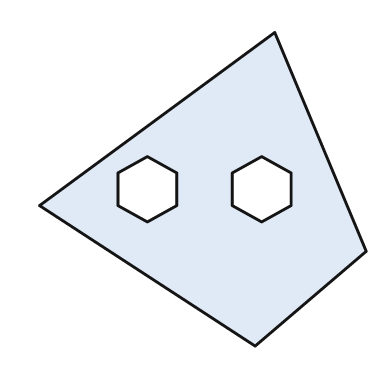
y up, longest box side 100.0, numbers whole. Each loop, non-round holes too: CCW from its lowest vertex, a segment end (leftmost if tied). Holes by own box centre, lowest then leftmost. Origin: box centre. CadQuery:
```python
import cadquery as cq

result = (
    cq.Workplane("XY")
    .moveTo(16.0, -48.0)
    .lineTo(50.0, -19.0)
    .lineTo(22.0, 48.0)
    .lineTo(-50.0, -5.0)
    .close()
    .moveTo(-17.0, -10.0)
    .lineTo(-8.0, -5.0)
    .lineTo(-8.0, 5.0)
    .lineTo(-17.0, 10.0)
    .lineTo(-26.0, 5.0)
    .lineTo(-26.0, -5.0)
    .close()
    .moveTo(18.0, -10.0)
    .lineTo(27.0, -5.0)
    .lineTo(27.0, 5.0)
    .lineTo(18.0, 10.0)
    .lineTo(9.0, 5.0)
    .lineTo(9.0, -5.0)
    .close()
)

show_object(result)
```